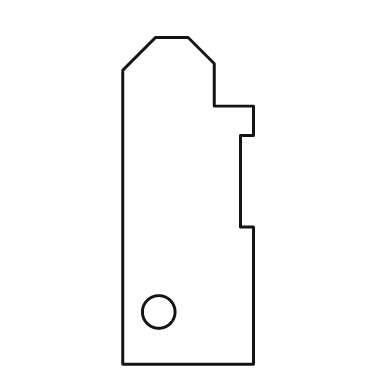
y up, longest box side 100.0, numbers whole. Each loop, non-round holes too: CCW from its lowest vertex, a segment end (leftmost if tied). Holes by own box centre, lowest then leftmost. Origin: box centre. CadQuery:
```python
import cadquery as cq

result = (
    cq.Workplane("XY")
    .moveTo(-20.0, -50.0)
    .lineTo(20.0, -50.0)
    .lineTo(20.0, -8.0)
    .lineTo(16.0, -8.0)
    .lineTo(16.0, 20.0)
    .lineTo(20.0, 20.0)
    .lineTo(20.0, 29.0)
    .lineTo(8.0, 29.0)
    .lineTo(8.0, 42.0)
    .lineTo(0.0, 50.0)
    .lineTo(-10.0, 50.0)
    .lineTo(-20.0, 40.0)
    .close()
    .moveTo(-9.0, -34.0)
    .circle(5.0)
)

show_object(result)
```